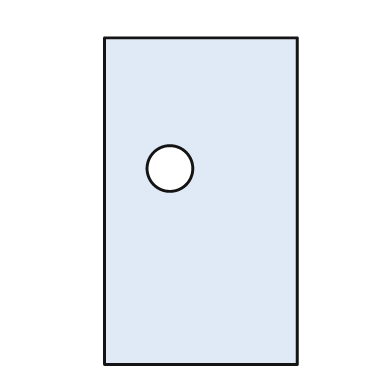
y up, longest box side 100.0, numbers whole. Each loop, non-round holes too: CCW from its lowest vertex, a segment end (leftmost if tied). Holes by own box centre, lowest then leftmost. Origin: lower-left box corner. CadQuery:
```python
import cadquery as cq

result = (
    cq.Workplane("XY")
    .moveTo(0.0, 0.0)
    .lineTo(59.0, 0.0)
    .lineTo(59.0, 100.0)
    .lineTo(0.0, 100.0)
    .close()
    .moveTo(20.0, 60.0)
    .circle(7.0)
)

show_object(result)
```